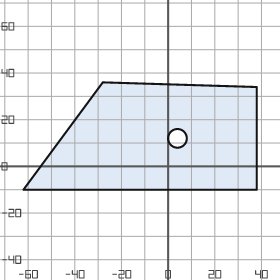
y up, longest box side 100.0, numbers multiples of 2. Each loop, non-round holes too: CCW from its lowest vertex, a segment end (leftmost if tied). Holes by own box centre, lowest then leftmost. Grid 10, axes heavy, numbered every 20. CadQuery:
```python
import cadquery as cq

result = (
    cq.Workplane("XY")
    .moveTo(-62.0, -10.0)
    .lineTo(38.0, -10.0)
    .lineTo(38.0, 34.0)
    .lineTo(-28.0, 36.0)
    .close()
    .moveTo(4.0, 12.0)
    .circle(4.0)
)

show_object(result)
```